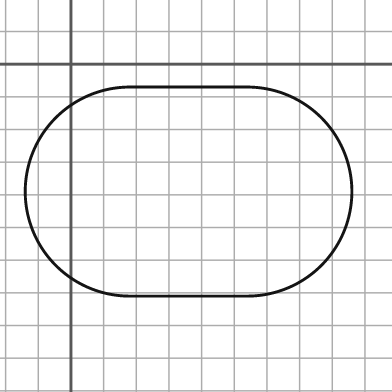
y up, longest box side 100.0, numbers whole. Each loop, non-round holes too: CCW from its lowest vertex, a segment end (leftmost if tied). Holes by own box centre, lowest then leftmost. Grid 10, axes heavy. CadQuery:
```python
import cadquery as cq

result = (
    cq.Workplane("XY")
    .moveTo(18.0, -71.0)
    .lineTo(54.0, -71.0)
    .threePointArc((86.0, -39.0), (54.0, -7.0))
    .lineTo(18.0, -7.0)
    .threePointArc((-14.0, -39.0), (18.0, -71.0))
    .close()
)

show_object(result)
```